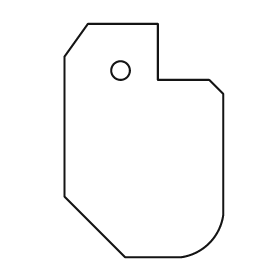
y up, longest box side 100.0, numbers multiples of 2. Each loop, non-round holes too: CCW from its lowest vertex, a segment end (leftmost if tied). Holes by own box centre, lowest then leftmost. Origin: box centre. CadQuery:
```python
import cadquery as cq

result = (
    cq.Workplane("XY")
    .moveTo(-8.0, -50.0)
    .lineTo(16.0, -50.0)
    .threePointArc((28.0, -44.0), (34.0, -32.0))
    .lineTo(34.0, 20.0)
    .lineTo(28.0, 26.0)
    .lineTo(6.0, 26.0)
    .lineTo(6.0, 50.0)
    .lineTo(-24.0, 50.0)
    .lineTo(-34.0, 36.0)
    .lineTo(-34.0, -24.0)
    .close()
    .moveTo(-10.0, 30.0)
    .circle(4.0)
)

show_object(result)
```